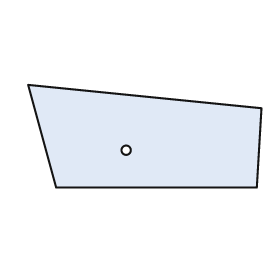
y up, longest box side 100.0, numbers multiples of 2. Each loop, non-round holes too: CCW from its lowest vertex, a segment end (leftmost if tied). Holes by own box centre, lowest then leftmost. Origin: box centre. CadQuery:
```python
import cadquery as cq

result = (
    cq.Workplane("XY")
    .moveTo(-38.0, -22.0)
    .lineTo(48.0, -22.0)
    .lineTo(50.0, 12.0)
    .lineTo(-50.0, 22.0)
    .close()
    .moveTo(-8.0, -6.0)
    .circle(2.0)
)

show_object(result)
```